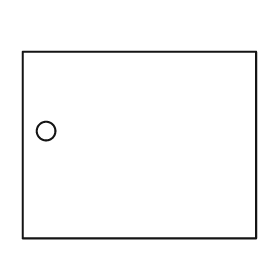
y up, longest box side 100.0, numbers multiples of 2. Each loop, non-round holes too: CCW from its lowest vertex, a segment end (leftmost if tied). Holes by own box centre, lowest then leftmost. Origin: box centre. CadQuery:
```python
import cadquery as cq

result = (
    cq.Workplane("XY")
    .moveTo(-50.0, -40.0)
    .lineTo(50.0, -40.0)
    .lineTo(50.0, 40.0)
    .lineTo(-50.0, 40.0)
    .close()
    .moveTo(-40.0, 6.0)
    .circle(4.0)
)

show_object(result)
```